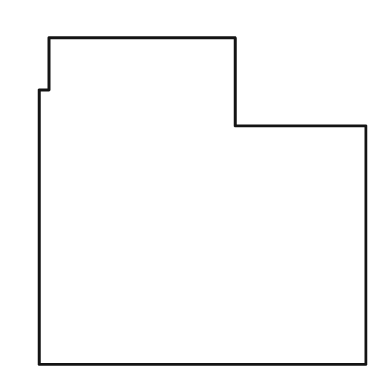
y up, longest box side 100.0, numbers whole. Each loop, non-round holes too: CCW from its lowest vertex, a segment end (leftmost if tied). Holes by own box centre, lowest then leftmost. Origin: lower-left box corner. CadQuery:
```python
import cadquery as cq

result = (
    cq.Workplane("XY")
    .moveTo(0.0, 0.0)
    .lineTo(100.0, 0.0)
    .lineTo(100.0, 73.0)
    .lineTo(60.0, 73.0)
    .lineTo(60.0, 100.0)
    .lineTo(3.0, 100.0)
    .lineTo(3.0, 84.0)
    .lineTo(0.0, 84.0)
    .close()
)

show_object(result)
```